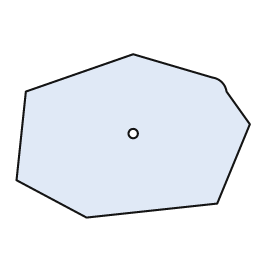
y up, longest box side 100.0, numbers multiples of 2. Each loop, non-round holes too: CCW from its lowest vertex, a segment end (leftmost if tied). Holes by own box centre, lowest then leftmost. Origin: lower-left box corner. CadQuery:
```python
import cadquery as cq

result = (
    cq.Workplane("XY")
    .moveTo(30.0, 0.0)
    .lineTo(86.0, 6.0)
    .lineTo(100.0, 40.0)
    .lineTo(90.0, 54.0)
    .threePointArc((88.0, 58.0), (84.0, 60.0))
    .lineTo(50.0, 70.0)
    .lineTo(4.0, 54.0)
    .lineTo(0.0, 16.0)
    .close()
    .moveTo(50.0, 36.0)
    .circle(2.0)
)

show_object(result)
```